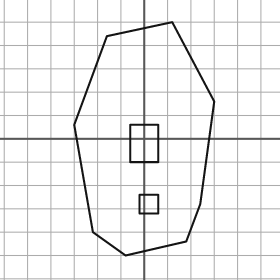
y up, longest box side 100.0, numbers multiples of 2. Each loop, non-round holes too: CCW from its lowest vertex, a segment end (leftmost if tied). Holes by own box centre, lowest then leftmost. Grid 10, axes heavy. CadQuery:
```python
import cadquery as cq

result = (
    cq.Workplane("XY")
    .moveTo(-8.0, -50.0)
    .lineTo(18.0, -44.0)
    .lineTo(24.0, -28.0)
    .lineTo(30.0, 16.0)
    .lineTo(12.0, 50.0)
    .lineTo(-16.0, 44.0)
    .lineTo(-30.0, 6.0)
    .lineTo(-22.0, -40.0)
    .close()
    .moveTo(-2.0, -32.0)
    .lineTo(6.0, -32.0)
    .lineTo(6.0, -24.0)
    .lineTo(-2.0, -24.0)
    .close()
    .moveTo(-6.0, -10.0)
    .lineTo(6.0, -10.0)
    .lineTo(6.0, 6.0)
    .lineTo(-6.0, 6.0)
    .close()
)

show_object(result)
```